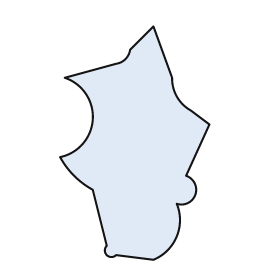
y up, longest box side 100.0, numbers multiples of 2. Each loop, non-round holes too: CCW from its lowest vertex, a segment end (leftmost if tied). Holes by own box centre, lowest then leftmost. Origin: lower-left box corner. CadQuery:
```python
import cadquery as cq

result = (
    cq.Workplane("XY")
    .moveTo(40.0, 0.0)
    .threePointArc((50.0, 10.0), (50.0, 24.0))
    .threePointArc((58.0, 28.0), (54.0, 36.0))
    .lineTo(64.0, 58.0)
    .lineTo(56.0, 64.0)
    .threePointArc((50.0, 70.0), (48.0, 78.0))
    .lineTo(40.0, 100.0)
    .lineTo(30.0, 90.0)
    .threePointArc((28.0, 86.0), (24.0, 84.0))
    .lineTo(2.0, 78.0)
    .threePointArc((14.0, 60.0), (0.0, 44.0))
    .threePointArc((6.0, 36.0), (14.0, 30.0))
    .lineTo(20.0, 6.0)
    .threePointArc((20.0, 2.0), (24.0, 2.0))
    .close()
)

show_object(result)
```